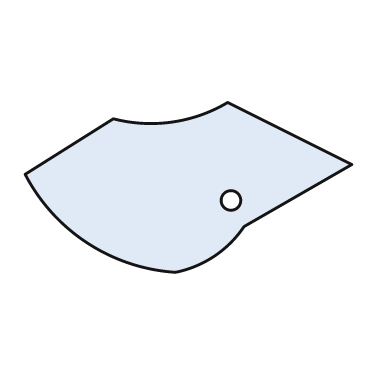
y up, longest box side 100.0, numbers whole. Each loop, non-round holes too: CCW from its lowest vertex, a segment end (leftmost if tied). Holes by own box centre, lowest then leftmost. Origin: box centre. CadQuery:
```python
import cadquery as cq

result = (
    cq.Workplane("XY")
    .moveTo(-4.0, -26.0)
    .threePointArc((8.0, -21.0), (17.0, -12.0))
    .lineTo(50.0, 7.0)
    .lineTo(12.0, 26.0)
    .threePointArc((-5.0, 20.0), (-23.0, 21.0))
    .lineTo(-50.0, 4.0)
    .threePointArc((-31.0, -17.0), (-4.0, -26.0))
    .close()
    .moveTo(13.0, -4.0)
    .circle(3.0)
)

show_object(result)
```